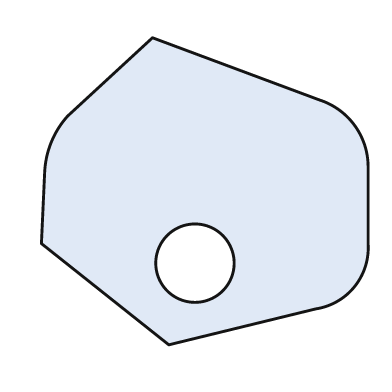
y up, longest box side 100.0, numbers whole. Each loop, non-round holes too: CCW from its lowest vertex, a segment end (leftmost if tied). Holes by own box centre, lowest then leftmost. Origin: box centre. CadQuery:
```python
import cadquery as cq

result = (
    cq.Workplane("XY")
    .moveTo(-11.0, -47.0)
    .lineTo(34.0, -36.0)
    .threePointArc((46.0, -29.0), (50.0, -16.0))
    .lineTo(50.0, 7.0)
    .threePointArc((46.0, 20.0), (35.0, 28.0))
    .lineTo(-16.0, 47.0)
    .lineTo(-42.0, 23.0)
    .threePointArc((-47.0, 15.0), (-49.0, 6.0))
    .lineTo(-50.0, -16.0)
    .close()
    .moveTo(-3.0, -22.0)
    .circle(12.0)
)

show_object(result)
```